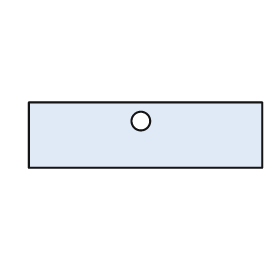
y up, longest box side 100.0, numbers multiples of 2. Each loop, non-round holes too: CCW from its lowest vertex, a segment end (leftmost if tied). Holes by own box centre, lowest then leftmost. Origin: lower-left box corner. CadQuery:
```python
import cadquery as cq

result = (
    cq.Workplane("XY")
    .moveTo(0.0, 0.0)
    .lineTo(100.0, 0.0)
    .lineTo(100.0, 28.0)
    .lineTo(0.0, 28.0)
    .close()
    .moveTo(48.0, 20.0)
    .circle(4.0)
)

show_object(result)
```